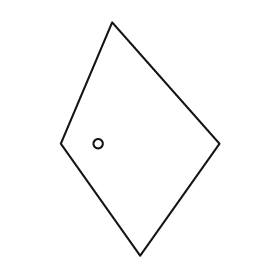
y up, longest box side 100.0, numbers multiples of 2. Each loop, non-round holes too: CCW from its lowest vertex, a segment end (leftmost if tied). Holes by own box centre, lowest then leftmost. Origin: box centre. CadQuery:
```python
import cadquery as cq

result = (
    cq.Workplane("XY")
    .moveTo(0.0, -50.0)
    .lineTo(34.0, -2.0)
    .lineTo(-12.0, 50.0)
    .lineTo(-34.0, -2.0)
    .close()
    .moveTo(-18.0, -2.0)
    .circle(2.0)
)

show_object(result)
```